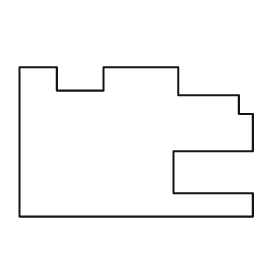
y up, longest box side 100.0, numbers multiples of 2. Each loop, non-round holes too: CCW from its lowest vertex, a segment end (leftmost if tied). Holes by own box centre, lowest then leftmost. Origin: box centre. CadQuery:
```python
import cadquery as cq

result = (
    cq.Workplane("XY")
    .moveTo(-50.0, -32.0)
    .lineTo(50.0, -32.0)
    .lineTo(50.0, -22.0)
    .lineTo(16.0, -22.0)
    .lineTo(16.0, -4.0)
    .lineTo(50.0, -4.0)
    .lineTo(50.0, 12.0)
    .lineTo(44.0, 12.0)
    .lineTo(44.0, 20.0)
    .lineTo(18.0, 20.0)
    .lineTo(18.0, 32.0)
    .lineTo(-14.0, 32.0)
    .lineTo(-14.0, 22.0)
    .lineTo(-34.0, 22.0)
    .lineTo(-34.0, 32.0)
    .lineTo(-50.0, 32.0)
    .close()
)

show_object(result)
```